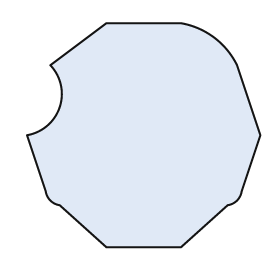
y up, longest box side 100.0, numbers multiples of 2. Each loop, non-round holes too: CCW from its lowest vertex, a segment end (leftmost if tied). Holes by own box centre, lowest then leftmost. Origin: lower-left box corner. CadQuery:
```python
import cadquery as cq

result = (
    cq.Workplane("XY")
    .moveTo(34.0, 0.0)
    .lineTo(66.0, 0.0)
    .lineTo(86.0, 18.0)
    .threePointArc((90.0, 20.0), (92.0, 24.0))
    .lineTo(100.0, 48.0)
    .lineTo(90.0, 78.0)
    .threePointArc((80.0, 90.0), (66.0, 96.0))
    .lineTo(34.0, 96.0)
    .lineTo(10.0, 78.0)
    .threePointArc((14.0, 60.0), (0.0, 48.0))
    .lineTo(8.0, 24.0)
    .threePointArc((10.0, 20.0), (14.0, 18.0))
    .close()
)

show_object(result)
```